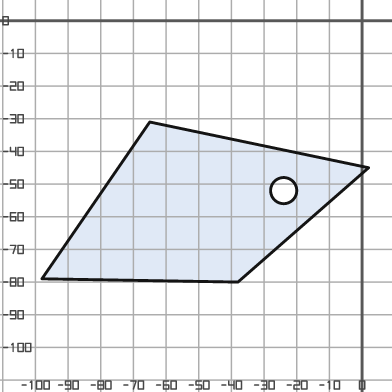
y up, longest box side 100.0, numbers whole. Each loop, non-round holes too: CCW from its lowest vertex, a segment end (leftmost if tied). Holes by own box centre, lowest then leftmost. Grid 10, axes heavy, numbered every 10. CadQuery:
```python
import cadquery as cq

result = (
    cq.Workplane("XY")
    .moveTo(-38.0, -80.0)
    .lineTo(2.0, -45.0)
    .lineTo(-65.0, -31.0)
    .lineTo(-98.0, -79.0)
    .close()
    .moveTo(-24.0, -52.0)
    .circle(4.0)
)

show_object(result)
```